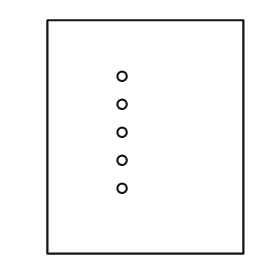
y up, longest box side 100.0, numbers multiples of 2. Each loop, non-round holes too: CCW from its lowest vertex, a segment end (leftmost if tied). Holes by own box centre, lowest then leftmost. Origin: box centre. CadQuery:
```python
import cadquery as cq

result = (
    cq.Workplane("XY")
    .moveTo(-42.0, -50.0)
    .lineTo(42.0, -50.0)
    .lineTo(42.0, 50.0)
    .lineTo(-42.0, 50.0)
    .close()
    .moveTo(-10.0, -22.0)
    .circle(2.0)
    .moveTo(-10.0, -10.0)
    .circle(2.0)
    .moveTo(-10.0, 2.0)
    .circle(2.0)
    .moveTo(-10.0, 14.0)
    .circle(2.0)
    .moveTo(-10.0, 26.0)
    .circle(2.0)
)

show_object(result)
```